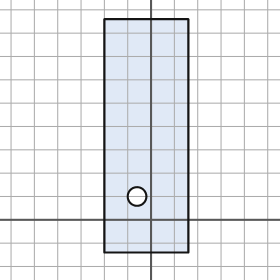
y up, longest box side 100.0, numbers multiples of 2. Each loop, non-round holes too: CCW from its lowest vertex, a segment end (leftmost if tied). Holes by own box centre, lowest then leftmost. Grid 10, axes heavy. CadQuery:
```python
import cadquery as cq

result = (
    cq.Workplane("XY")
    .moveTo(-20.0, -14.0)
    .lineTo(16.0, -14.0)
    .lineTo(16.0, 86.0)
    .lineTo(-20.0, 86.0)
    .close()
    .moveTo(-6.0, 10.0)
    .circle(4.0)
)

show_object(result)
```